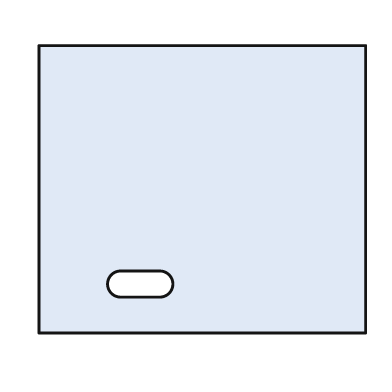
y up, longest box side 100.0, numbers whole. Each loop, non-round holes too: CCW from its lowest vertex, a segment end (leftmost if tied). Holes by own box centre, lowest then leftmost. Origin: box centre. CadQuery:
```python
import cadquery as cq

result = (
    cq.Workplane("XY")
    .moveTo(-50.0, -44.0)
    .lineTo(50.0, -44.0)
    .lineTo(50.0, 44.0)
    .lineTo(-50.0, 44.0)
    .close()
    .moveTo(-25.0, -33.0)
    .lineTo(-13.0, -33.0)
    .threePointArc((-9.0, -29.0), (-13.0, -25.0))
    .lineTo(-25.0, -25.0)
    .threePointArc((-29.0, -29.0), (-25.0, -33.0))
    .close()
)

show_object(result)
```